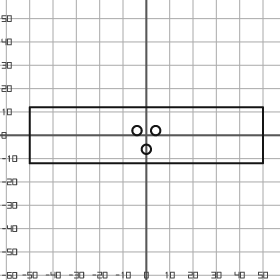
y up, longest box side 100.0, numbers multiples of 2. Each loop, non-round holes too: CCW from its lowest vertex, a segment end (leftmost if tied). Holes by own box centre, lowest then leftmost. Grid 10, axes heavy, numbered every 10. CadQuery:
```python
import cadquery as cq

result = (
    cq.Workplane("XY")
    .moveTo(-50.0, -12.0)
    .lineTo(50.0, -12.0)
    .lineTo(50.0, 12.0)
    .lineTo(-50.0, 12.0)
    .close()
    .moveTo(0.0, -6.0)
    .circle(2.0)
    .moveTo(-4.0, 2.0)
    .circle(2.0)
    .moveTo(4.0, 2.0)
    .circle(2.0)
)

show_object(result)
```